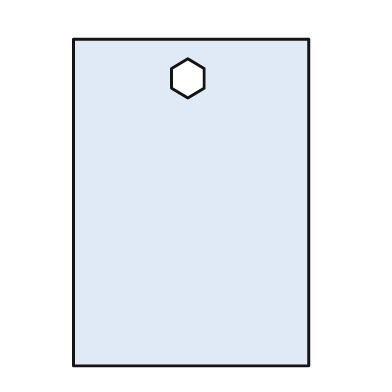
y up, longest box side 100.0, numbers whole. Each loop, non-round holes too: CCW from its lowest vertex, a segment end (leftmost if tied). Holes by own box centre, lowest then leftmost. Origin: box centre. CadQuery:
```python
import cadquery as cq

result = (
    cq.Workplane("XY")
    .moveTo(-36.0, -50.0)
    .lineTo(36.0, -50.0)
    .lineTo(36.0, 50.0)
    .lineTo(-36.0, 50.0)
    .close()
    .moveTo(-1.0, 32.0)
    .lineTo(4.0, 35.0)
    .lineTo(4.0, 41.0)
    .lineTo(-1.0, 44.0)
    .lineTo(-6.0, 41.0)
    .lineTo(-6.0, 35.0)
    .close()
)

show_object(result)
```